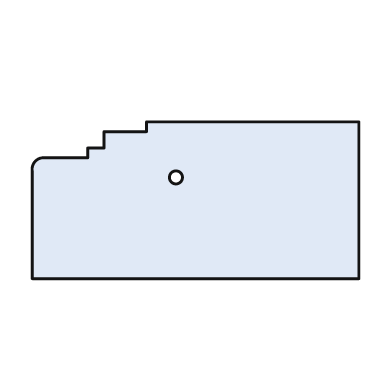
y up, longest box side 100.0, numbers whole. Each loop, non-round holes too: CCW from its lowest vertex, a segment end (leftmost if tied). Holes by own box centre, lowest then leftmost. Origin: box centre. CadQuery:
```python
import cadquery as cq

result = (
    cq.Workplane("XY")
    .moveTo(-50.0, -24.0)
    .lineTo(50.0, -24.0)
    .lineTo(50.0, 24.0)
    .lineTo(-15.0, 24.0)
    .lineTo(-15.0, 21.0)
    .lineTo(-28.0, 21.0)
    .lineTo(-28.0, 16.0)
    .lineTo(-33.0, 16.0)
    .lineTo(-33.0, 13.0)
    .lineTo(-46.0, 13.0)
    .threePointArc((-49.0, 12.0), (-50.0, 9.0))
    .close()
    .moveTo(-6.0, 7.0)
    .circle(2.0)
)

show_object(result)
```